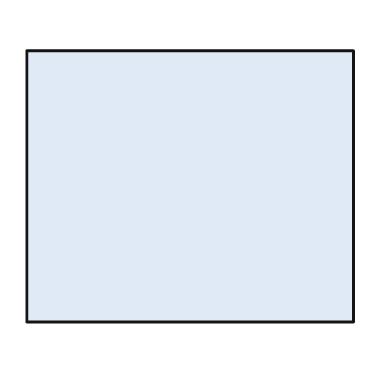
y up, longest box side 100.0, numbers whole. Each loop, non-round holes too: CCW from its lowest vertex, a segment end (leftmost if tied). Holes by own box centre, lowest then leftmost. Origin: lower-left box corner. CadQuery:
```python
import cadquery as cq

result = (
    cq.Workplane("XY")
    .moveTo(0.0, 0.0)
    .lineTo(100.0, 0.0)
    .lineTo(100.0, 83.0)
    .lineTo(0.0, 83.0)
    .close()
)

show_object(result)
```